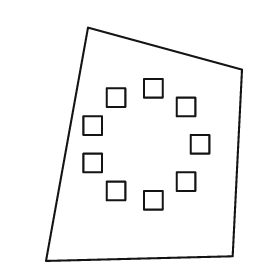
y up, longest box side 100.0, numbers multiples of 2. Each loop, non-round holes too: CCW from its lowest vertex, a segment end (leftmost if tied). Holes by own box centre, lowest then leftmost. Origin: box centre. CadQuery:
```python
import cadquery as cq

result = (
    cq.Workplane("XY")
    .moveTo(-42.0, -50.0)
    .lineTo(38.0, -48.0)
    .lineTo(42.0, 32.0)
    .lineTo(-24.0, 50.0)
    .close()
    .moveTo(0.0, -28.0)
    .lineTo(8.0, -28.0)
    .lineTo(8.0, -20.0)
    .lineTo(0.0, -20.0)
    .close()
    .moveTo(-16.0, -24.0)
    .lineTo(-8.0, -24.0)
    .lineTo(-8.0, -16.0)
    .lineTo(-16.0, -16.0)
    .close()
    .moveTo(14.0, -20.0)
    .lineTo(22.0, -20.0)
    .lineTo(22.0, -12.0)
    .lineTo(14.0, -12.0)
    .close()
    .moveTo(-26.0, -12.0)
    .lineTo(-18.0, -12.0)
    .lineTo(-18.0, -4.0)
    .lineTo(-26.0, -4.0)
    .close()
    .moveTo(20.0, -4.0)
    .lineTo(28.0, -4.0)
    .lineTo(28.0, 4.0)
    .lineTo(20.0, 4.0)
    .close()
    .moveTo(-26.0, 4.0)
    .lineTo(-18.0, 4.0)
    .lineTo(-18.0, 12.0)
    .lineTo(-26.0, 12.0)
    .close()
    .moveTo(14.0, 12.0)
    .lineTo(22.0, 12.0)
    .lineTo(22.0, 20.0)
    .lineTo(14.0, 20.0)
    .close()
    .moveTo(-16.0, 16.0)
    .lineTo(-8.0, 16.0)
    .lineTo(-8.0, 24.0)
    .lineTo(-16.0, 24.0)
    .close()
    .moveTo(0.0, 20.0)
    .lineTo(8.0, 20.0)
    .lineTo(8.0, 28.0)
    .lineTo(0.0, 28.0)
    .close()
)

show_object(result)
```